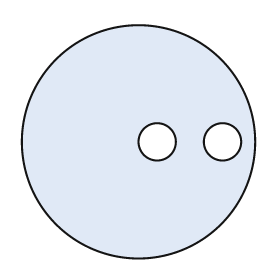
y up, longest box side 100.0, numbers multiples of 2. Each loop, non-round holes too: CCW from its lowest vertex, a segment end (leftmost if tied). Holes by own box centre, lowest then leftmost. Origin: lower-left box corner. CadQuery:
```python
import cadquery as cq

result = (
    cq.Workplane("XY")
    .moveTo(50.0, 50.0)
    .circle(50.0)
    .moveTo(58.0, 50.0)
    .circle(8.0)
    .moveTo(86.0, 50.0)
    .circle(8.0)
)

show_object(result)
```